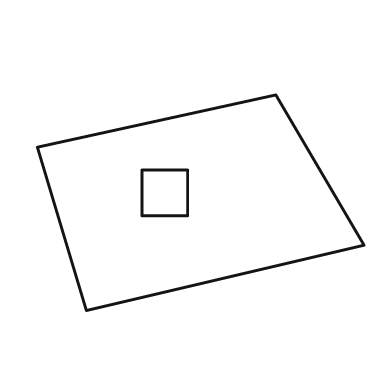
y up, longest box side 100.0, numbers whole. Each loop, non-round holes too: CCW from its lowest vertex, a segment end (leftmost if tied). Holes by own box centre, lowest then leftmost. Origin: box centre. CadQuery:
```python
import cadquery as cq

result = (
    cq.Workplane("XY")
    .moveTo(-35.0, -33.0)
    .lineTo(50.0, -13.0)
    .lineTo(23.0, 33.0)
    .lineTo(-50.0, 17.0)
    .close()
    .moveTo(-18.0, -4.0)
    .lineTo(-4.0, -4.0)
    .lineTo(-4.0, 10.0)
    .lineTo(-18.0, 10.0)
    .close()
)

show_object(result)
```